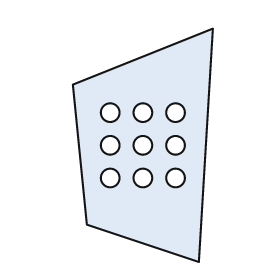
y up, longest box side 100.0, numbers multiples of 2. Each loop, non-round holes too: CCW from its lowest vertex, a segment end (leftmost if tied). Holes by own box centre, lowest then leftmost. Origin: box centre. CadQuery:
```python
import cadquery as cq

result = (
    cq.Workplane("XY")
    .moveTo(24.0, -50.0)
    .lineTo(30.0, 50.0)
    .lineTo(-30.0, 26.0)
    .lineTo(-24.0, -34.0)
    .close()
    .moveTo(-14.0, -14.0)
    .circle(4.0)
    .moveTo(0.0, -14.0)
    .circle(4.0)
    .moveTo(14.0, -14.0)
    .circle(4.0)
    .moveTo(-14.0, 0.0)
    .circle(4.0)
    .moveTo(0.0, 0.0)
    .circle(4.0)
    .moveTo(14.0, 0.0)
    .circle(4.0)
    .moveTo(-14.0, 14.0)
    .circle(4.0)
    .moveTo(0.0, 14.0)
    .circle(4.0)
    .moveTo(14.0, 14.0)
    .circle(4.0)
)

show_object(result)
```